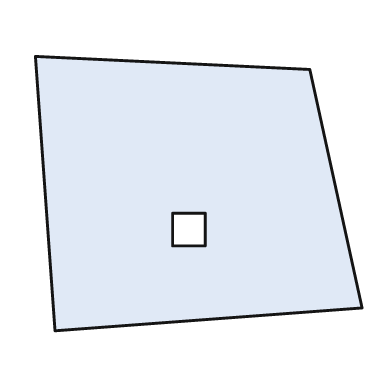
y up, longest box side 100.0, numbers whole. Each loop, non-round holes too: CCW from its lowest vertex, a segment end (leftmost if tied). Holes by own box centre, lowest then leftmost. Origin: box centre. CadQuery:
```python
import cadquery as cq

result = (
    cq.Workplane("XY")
    .moveTo(-44.0, -42.0)
    .lineTo(50.0, -35.0)
    .lineTo(34.0, 38.0)
    .lineTo(-50.0, 42.0)
    .close()
    .moveTo(-8.0, -16.0)
    .lineTo(2.0, -16.0)
    .lineTo(2.0, -6.0)
    .lineTo(-8.0, -6.0)
    .close()
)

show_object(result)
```